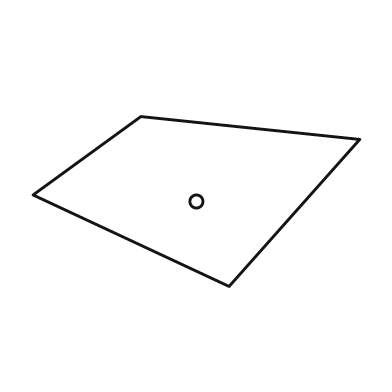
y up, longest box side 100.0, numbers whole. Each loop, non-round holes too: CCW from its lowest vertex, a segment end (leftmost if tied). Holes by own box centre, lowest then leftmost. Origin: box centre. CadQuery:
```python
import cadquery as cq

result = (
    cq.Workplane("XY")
    .moveTo(10.0, -26.0)
    .lineTo(50.0, 19.0)
    .lineTo(-17.0, 26.0)
    .lineTo(-50.0, 2.0)
    .close()
    .moveTo(0.0, 0.0)
    .circle(2.0)
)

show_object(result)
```